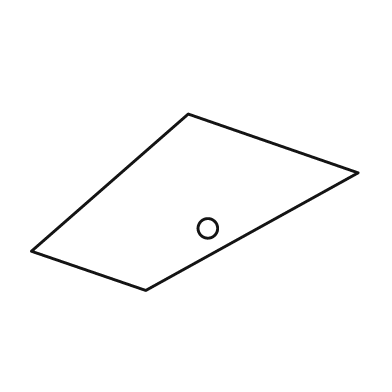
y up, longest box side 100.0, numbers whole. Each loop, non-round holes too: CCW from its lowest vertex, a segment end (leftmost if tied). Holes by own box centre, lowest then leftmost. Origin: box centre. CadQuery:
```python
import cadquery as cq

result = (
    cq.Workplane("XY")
    .moveTo(-15.0, -27.0)
    .lineTo(50.0, 9.0)
    .lineTo(-2.0, 27.0)
    .lineTo(-50.0, -15.0)
    .close()
    .moveTo(4.0, -8.0)
    .circle(3.0)
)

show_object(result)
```